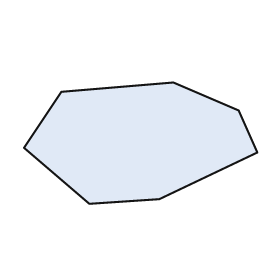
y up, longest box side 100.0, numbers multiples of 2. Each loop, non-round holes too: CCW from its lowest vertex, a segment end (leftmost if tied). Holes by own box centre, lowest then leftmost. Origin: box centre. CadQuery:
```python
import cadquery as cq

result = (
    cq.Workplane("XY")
    .moveTo(-22.0, -26.0)
    .lineTo(8.0, -24.0)
    .lineTo(50.0, -4.0)
    .lineTo(42.0, 14.0)
    .lineTo(14.0, 26.0)
    .lineTo(-34.0, 22.0)
    .lineTo(-50.0, -2.0)
    .close()
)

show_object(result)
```